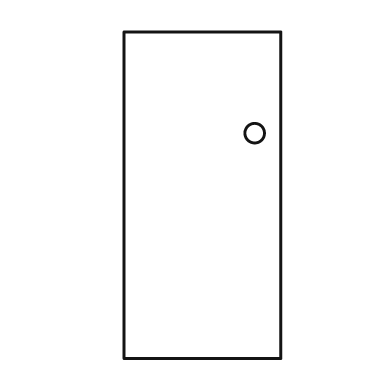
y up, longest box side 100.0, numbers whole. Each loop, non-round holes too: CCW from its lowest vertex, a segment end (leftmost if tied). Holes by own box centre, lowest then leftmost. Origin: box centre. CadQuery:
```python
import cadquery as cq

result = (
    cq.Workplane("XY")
    .moveTo(-24.0, -50.0)
    .lineTo(24.0, -50.0)
    .lineTo(24.0, 50.0)
    .lineTo(-24.0, 50.0)
    .close()
    .moveTo(16.0, 19.0)
    .circle(3.0)
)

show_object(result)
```